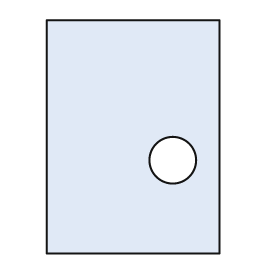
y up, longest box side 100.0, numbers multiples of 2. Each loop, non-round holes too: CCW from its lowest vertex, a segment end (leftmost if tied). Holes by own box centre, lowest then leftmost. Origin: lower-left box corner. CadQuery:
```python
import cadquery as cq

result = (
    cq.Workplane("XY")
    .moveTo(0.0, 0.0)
    .lineTo(74.0, 0.0)
    .lineTo(74.0, 100.0)
    .lineTo(0.0, 100.0)
    .close()
    .moveTo(54.0, 40.0)
    .circle(10.0)
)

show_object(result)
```